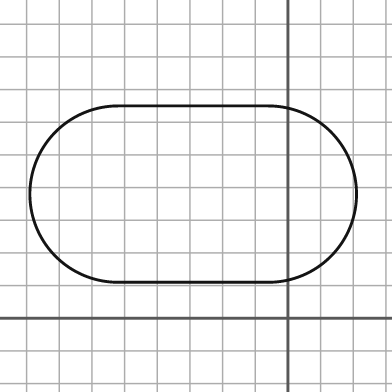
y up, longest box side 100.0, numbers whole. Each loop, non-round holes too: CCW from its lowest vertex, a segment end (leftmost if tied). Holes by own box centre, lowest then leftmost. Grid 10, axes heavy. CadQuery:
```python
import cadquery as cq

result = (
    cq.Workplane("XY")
    .moveTo(-52.0, 11.0)
    .lineTo(-6.0, 11.0)
    .threePointArc((21.0, 38.0), (-6.0, 65.0))
    .lineTo(-52.0, 65.0)
    .threePointArc((-79.0, 38.0), (-52.0, 11.0))
    .close()
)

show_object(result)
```